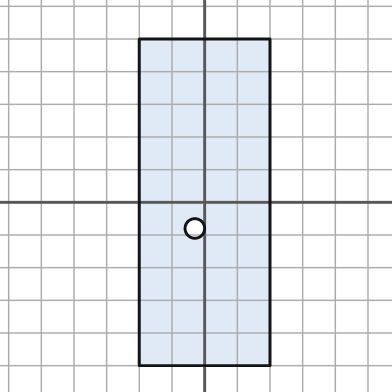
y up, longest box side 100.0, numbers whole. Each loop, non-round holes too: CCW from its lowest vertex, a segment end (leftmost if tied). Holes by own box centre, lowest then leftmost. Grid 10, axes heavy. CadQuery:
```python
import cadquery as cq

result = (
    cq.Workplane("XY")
    .moveTo(-20.0, -50.0)
    .lineTo(20.0, -50.0)
    .lineTo(20.0, 50.0)
    .lineTo(-20.0, 50.0)
    .close()
    .moveTo(-3.0, -8.0)
    .circle(3.0)
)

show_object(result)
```